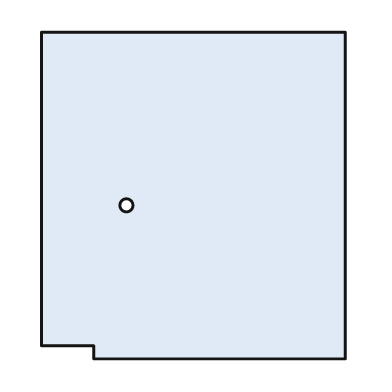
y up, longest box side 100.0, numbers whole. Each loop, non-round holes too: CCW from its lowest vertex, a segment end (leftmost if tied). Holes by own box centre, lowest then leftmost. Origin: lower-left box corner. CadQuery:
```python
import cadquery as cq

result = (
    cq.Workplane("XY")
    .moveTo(16.0, 0.0)
    .lineTo(93.0, 0.0)
    .lineTo(93.0, 100.0)
    .lineTo(0.0, 100.0)
    .lineTo(0.0, 4.0)
    .lineTo(16.0, 4.0)
    .close()
    .moveTo(26.0, 47.0)
    .circle(2.0)
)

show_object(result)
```